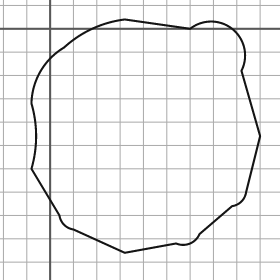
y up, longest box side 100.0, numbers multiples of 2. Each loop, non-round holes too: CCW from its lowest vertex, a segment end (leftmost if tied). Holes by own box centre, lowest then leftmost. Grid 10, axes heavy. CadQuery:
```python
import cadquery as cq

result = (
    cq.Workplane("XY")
    .moveTo(32.0, -96.0)
    .lineTo(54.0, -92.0)
    .threePointArc((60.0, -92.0), (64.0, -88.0))
    .lineTo(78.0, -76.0)
    .threePointArc((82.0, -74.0), (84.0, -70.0))
    .lineTo(90.0, -46.0)
    .lineTo(82.0, -18.0)
    .threePointArc((78.0, 0.0), (60.0, 0.0))
    .lineTo(32.0, 4.0)
    .threePointArc((18.0, 0.0), (6.0, -8.0))
    .threePointArc((-4.0, -18.0), (-8.0, -32.0))
    .threePointArc((-6.0, -46.0), (-8.0, -60.0))
    .lineTo(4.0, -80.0)
    .threePointArc((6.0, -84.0), (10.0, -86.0))
    .close()
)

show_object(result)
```